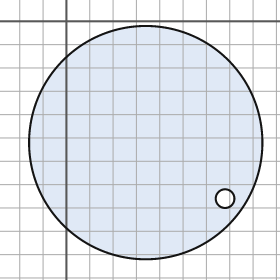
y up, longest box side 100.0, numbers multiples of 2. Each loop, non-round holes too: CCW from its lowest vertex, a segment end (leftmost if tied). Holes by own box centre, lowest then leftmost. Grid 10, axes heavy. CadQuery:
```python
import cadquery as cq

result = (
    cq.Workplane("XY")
    .moveTo(34.0, -52.0)
    .circle(50.0)
    .moveTo(68.0, -76.0)
    .circle(4.0)
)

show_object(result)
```